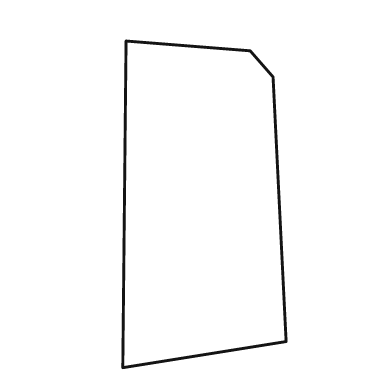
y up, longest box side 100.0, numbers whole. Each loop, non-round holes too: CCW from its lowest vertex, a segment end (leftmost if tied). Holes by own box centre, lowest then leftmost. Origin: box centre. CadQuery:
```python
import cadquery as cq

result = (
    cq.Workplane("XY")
    .moveTo(-25.0, -50.0)
    .lineTo(25.0, -42.0)
    .lineTo(21.0, 39.0)
    .lineTo(14.0, 47.0)
    .lineTo(-24.0, 50.0)
    .close()
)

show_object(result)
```